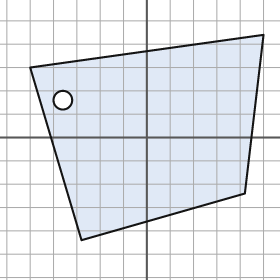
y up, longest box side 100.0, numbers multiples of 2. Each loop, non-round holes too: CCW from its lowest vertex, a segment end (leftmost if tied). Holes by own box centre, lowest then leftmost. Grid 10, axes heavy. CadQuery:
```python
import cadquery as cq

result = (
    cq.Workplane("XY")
    .moveTo(-28.0, -44.0)
    .lineTo(42.0, -24.0)
    .lineTo(50.0, 44.0)
    .lineTo(-50.0, 30.0)
    .close()
    .moveTo(-36.0, 16.0)
    .circle(4.0)
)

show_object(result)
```